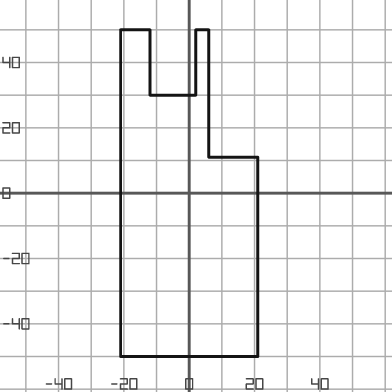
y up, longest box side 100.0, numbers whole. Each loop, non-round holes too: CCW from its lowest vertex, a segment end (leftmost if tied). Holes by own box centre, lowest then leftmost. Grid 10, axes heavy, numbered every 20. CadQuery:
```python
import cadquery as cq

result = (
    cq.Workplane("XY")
    .moveTo(-21.0, -50.0)
    .lineTo(21.0, -50.0)
    .lineTo(21.0, 11.0)
    .lineTo(6.0, 11.0)
    .lineTo(6.0, 50.0)
    .lineTo(2.0, 50.0)
    .lineTo(2.0, 30.0)
    .lineTo(-12.0, 30.0)
    .lineTo(-12.0, 50.0)
    .lineTo(-21.0, 50.0)
    .close()
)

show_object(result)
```